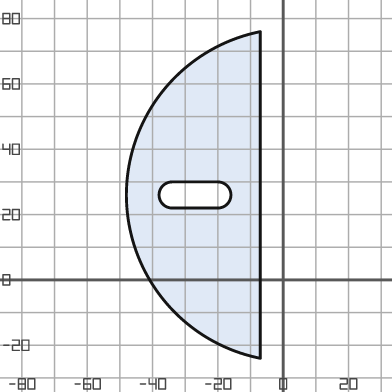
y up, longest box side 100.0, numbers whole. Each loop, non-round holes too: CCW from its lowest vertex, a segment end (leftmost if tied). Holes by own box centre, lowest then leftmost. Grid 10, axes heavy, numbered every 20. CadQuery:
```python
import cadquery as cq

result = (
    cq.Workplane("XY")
    .moveTo(-7.0, -24.0)
    .lineTo(-7.0, 76.0)
    .threePointArc((-48.0, 26.0), (-7.0, -24.0))
    .close()
    .moveTo(-34.0, 22.0)
    .lineTo(-20.0, 22.0)
    .threePointArc((-16.0, 26.0), (-20.0, 30.0))
    .lineTo(-34.0, 30.0)
    .threePointArc((-38.0, 26.0), (-34.0, 22.0))
    .close()
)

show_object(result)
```